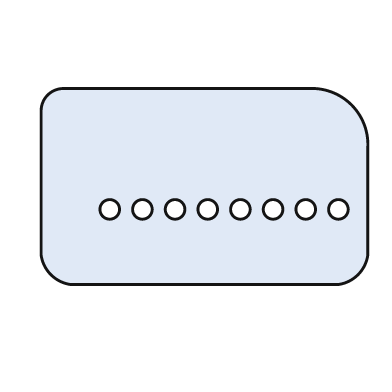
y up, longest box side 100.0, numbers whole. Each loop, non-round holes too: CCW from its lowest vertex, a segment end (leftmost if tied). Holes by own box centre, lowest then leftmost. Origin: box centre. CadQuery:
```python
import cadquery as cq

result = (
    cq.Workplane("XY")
    .moveTo(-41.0, -30.0)
    .lineTo(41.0, -30.0)
    .threePointArc((47.0, -27.0), (50.0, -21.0))
    .lineTo(50.0, 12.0)
    .threePointArc((45.0, 25.0), (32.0, 30.0))
    .lineTo(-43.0, 30.0)
    .threePointArc((-48.0, 28.0), (-50.0, 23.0))
    .lineTo(-50.0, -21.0)
    .threePointArc((-47.0, -27.0), (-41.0, -30.0))
    .close()
    .moveTo(-29.0, -7.0)
    .circle(3.0)
    .moveTo(-19.0, -7.0)
    .circle(3.0)
    .moveTo(-9.0, -7.0)
    .circle(3.0)
    .moveTo(1.0, -7.0)
    .circle(3.0)
    .moveTo(11.0, -7.0)
    .circle(3.0)
    .moveTo(21.0, -7.0)
    .circle(3.0)
    .moveTo(31.0, -7.0)
    .circle(3.0)
    .moveTo(41.0, -7.0)
    .circle(3.0)
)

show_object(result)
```